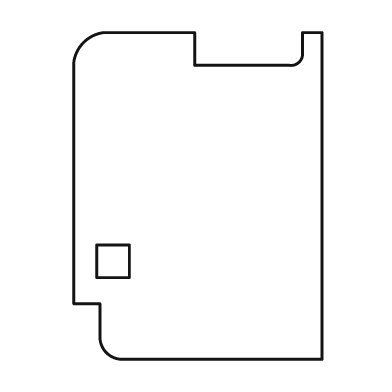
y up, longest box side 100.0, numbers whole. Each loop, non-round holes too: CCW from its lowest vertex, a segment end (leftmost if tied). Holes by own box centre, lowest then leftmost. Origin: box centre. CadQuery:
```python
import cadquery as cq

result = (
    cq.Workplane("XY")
    .moveTo(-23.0, -50.0)
    .lineTo(38.0, -50.0)
    .lineTo(38.0, 50.0)
    .lineTo(32.0, 50.0)
    .lineTo(32.0, 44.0)
    .threePointArc((31.0, 41.0), (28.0, 40.0))
    .lineTo(-1.0, 40.0)
    .lineTo(-1.0, 50.0)
    .lineTo(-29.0, 50.0)
    .threePointArc((-35.0, 47.0), (-38.0, 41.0))
    .lineTo(-38.0, -33.0)
    .lineTo(-30.0, -33.0)
    .lineTo(-30.0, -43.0)
    .threePointArc((-28.0, -48.0), (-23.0, -50.0))
    .close()
    .moveTo(-31.0, -25.0)
    .lineTo(-21.0, -25.0)
    .lineTo(-21.0, -15.0)
    .lineTo(-31.0, -15.0)
    .close()
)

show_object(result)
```